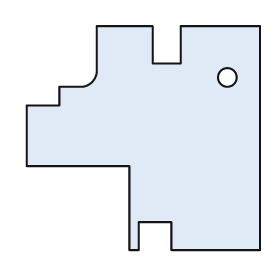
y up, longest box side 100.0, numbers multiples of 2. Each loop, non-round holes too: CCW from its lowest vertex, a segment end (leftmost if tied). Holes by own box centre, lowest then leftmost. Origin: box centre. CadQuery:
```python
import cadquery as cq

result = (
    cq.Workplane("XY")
    .moveTo(-6.0, -48.0)
    .lineTo(-2.0, -48.0)
    .lineTo(-2.0, -36.0)
    .lineTo(12.0, -36.0)
    .lineTo(12.0, -48.0)
    .lineTo(50.0, -48.0)
    .lineTo(50.0, 48.0)
    .lineTo(16.0, 48.0)
    .lineTo(16.0, 32.0)
    .lineTo(4.0, 32.0)
    .lineTo(4.0, 48.0)
    .lineTo(-20.0, 48.0)
    .lineTo(-20.0, 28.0)
    .threePointArc((-22.0, 24.0), (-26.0, 22.0))
    .lineTo(-36.0, 22.0)
    .lineTo(-36.0, 14.0)
    .lineTo(-50.0, 14.0)
    .lineTo(-50.0, -12.0)
    .lineTo(-6.0, -12.0)
    .close()
    .moveTo(36.0, 26.0)
    .circle(4.0)
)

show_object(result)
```